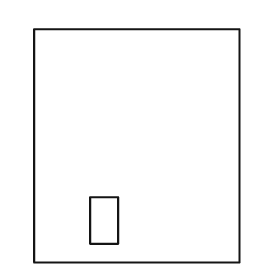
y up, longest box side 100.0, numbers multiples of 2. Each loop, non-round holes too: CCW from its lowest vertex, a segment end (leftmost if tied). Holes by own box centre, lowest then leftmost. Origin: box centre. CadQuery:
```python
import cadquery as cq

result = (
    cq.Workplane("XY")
    .moveTo(-44.0, -50.0)
    .lineTo(44.0, -50.0)
    .lineTo(44.0, 50.0)
    .lineTo(-44.0, 50.0)
    .close()
    .moveTo(-20.0, -42.0)
    .lineTo(-8.0, -42.0)
    .lineTo(-8.0, -22.0)
    .lineTo(-20.0, -22.0)
    .close()
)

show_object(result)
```